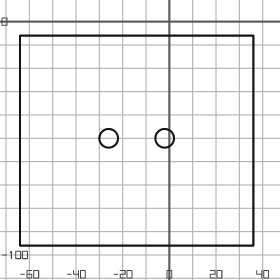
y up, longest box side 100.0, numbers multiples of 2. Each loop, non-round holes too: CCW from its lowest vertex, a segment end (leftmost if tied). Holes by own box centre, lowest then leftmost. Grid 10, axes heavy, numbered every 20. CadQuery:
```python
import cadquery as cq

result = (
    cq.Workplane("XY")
    .moveTo(-64.0, -96.0)
    .lineTo(36.0, -96.0)
    .lineTo(36.0, -6.0)
    .lineTo(-64.0, -6.0)
    .close()
    .moveTo(-26.0, -50.0)
    .circle(4.0)
    .moveTo(-2.0, -50.0)
    .circle(4.0)
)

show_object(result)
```